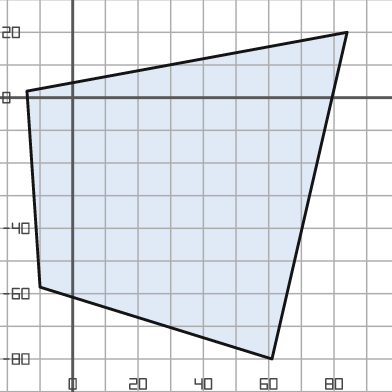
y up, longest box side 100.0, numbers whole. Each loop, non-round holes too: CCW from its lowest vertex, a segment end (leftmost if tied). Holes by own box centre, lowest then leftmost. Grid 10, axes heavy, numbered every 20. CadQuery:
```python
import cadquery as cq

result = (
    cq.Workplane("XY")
    .moveTo(61.0, -80.0)
    .lineTo(84.0, 20.0)
    .lineTo(-14.0, 2.0)
    .lineTo(-10.0, -58.0)
    .close()
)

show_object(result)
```